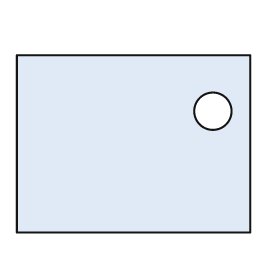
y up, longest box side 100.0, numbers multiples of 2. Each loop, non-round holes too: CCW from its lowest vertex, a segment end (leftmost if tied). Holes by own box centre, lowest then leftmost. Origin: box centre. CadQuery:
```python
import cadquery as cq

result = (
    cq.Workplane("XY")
    .moveTo(-50.0, -38.0)
    .lineTo(50.0, -38.0)
    .lineTo(50.0, 38.0)
    .lineTo(-50.0, 38.0)
    .close()
    .moveTo(34.0, 14.0)
    .circle(8.0)
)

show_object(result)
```